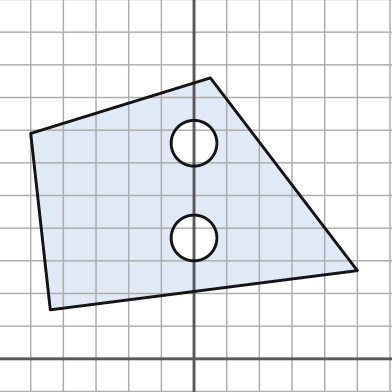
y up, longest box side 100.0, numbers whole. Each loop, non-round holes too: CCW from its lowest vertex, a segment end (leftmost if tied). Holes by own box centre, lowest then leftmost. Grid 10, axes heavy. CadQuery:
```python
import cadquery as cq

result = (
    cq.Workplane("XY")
    .moveTo(-44.0, 15.0)
    .lineTo(50.0, 27.0)
    .lineTo(5.0, 86.0)
    .lineTo(-50.0, 69.0)
    .close()
    .moveTo(0.0, 37.0)
    .circle(7.0)
    .moveTo(0.0, 66.0)
    .circle(7.0)
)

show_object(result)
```